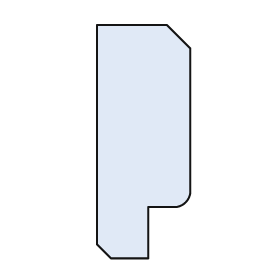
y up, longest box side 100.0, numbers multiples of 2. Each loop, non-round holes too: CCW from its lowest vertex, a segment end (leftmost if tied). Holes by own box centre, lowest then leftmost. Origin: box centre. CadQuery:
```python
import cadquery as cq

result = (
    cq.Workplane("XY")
    .moveTo(-14.0, -50.0)
    .lineTo(2.0, -50.0)
    .lineTo(2.0, -28.0)
    .lineTo(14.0, -28.0)
    .threePointArc((18.0, -26.0), (20.0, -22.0))
    .lineTo(20.0, 40.0)
    .lineTo(10.0, 50.0)
    .lineTo(-20.0, 50.0)
    .lineTo(-20.0, -44.0)
    .close()
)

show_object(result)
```